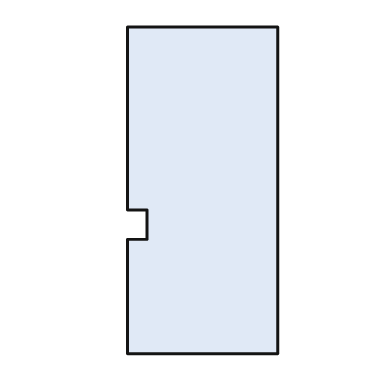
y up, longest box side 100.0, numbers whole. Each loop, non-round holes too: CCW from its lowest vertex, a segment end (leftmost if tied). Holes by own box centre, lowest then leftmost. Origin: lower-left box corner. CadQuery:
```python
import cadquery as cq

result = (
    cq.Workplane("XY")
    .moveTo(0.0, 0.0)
    .lineTo(46.0, 0.0)
    .lineTo(46.0, 100.0)
    .lineTo(0.0, 100.0)
    .lineTo(0.0, 44.0)
    .lineTo(6.0, 44.0)
    .lineTo(6.0, 35.0)
    .lineTo(0.0, 35.0)
    .close()
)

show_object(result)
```